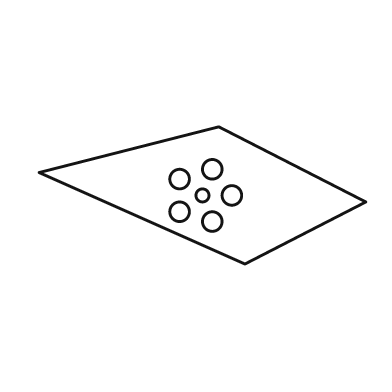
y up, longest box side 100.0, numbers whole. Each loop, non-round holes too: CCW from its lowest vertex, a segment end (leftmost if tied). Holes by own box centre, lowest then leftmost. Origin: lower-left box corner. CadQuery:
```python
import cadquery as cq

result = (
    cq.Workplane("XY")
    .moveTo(63.0, 0.0)
    .lineTo(100.0, 19.0)
    .lineTo(55.0, 42.0)
    .lineTo(0.0, 28.0)
    .close()
    .moveTo(53.0, 13.0)
    .circle(3.0)
    .moveTo(43.0, 16.0)
    .circle(3.0)
    .moveTo(50.0, 21.0)
    .circle(2.0)
    .moveTo(59.0, 21.0)
    .circle(3.0)
    .moveTo(43.0, 26.0)
    .circle(3.0)
    .moveTo(53.0, 29.0)
    .circle(3.0)
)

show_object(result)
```